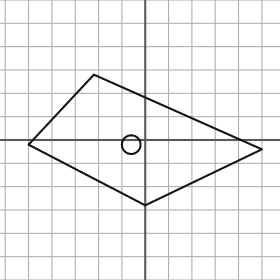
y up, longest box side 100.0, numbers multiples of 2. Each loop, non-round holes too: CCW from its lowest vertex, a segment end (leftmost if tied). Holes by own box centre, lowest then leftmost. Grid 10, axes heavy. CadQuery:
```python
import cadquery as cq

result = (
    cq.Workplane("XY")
    .moveTo(0.0, -28.0)
    .lineTo(50.0, -4.0)
    .lineTo(-22.0, 28.0)
    .lineTo(-50.0, -2.0)
    .close()
    .moveTo(-6.0, -2.0)
    .circle(4.0)
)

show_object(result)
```